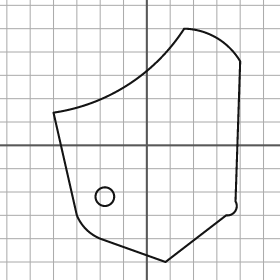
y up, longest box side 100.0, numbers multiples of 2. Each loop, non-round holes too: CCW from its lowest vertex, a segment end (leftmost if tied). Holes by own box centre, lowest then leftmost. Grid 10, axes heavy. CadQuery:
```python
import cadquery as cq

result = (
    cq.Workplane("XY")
    .moveTo(8.0, -50.0)
    .lineTo(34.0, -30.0)
    .threePointArc((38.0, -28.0), (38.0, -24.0))
    .lineTo(40.0, 36.0)
    .threePointArc((30.0, 46.0), (16.0, 50.0))
    .threePointArc((-8.0, 26.0), (-40.0, 14.0))
    .lineTo(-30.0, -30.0)
    .threePointArc((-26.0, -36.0), (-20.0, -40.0))
    .close()
    .moveTo(-18.0, -22.0)
    .circle(4.0)
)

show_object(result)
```